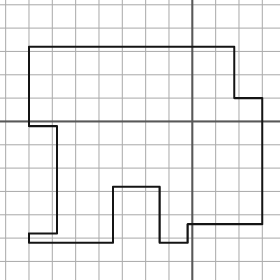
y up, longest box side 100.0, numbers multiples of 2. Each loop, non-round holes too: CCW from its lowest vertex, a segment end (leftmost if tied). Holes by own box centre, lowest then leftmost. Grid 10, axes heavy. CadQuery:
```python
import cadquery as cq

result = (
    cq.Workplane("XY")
    .moveTo(-70.0, -52.0)
    .lineTo(-34.0, -52.0)
    .lineTo(-34.0, -28.0)
    .lineTo(-14.0, -28.0)
    .lineTo(-14.0, -52.0)
    .lineTo(-2.0, -52.0)
    .lineTo(-2.0, -44.0)
    .lineTo(30.0, -44.0)
    .lineTo(30.0, 10.0)
    .lineTo(18.0, 10.0)
    .lineTo(18.0, 32.0)
    .lineTo(-70.0, 32.0)
    .lineTo(-70.0, -2.0)
    .lineTo(-58.0, -2.0)
    .lineTo(-58.0, -48.0)
    .lineTo(-70.0, -48.0)
    .close()
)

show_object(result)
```